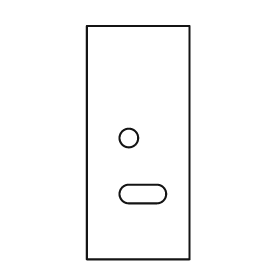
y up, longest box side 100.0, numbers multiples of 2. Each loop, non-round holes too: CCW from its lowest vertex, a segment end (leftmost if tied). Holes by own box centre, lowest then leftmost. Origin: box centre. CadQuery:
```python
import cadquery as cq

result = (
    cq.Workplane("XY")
    .moveTo(-22.0, -50.0)
    .lineTo(22.0, -50.0)
    .lineTo(22.0, 50.0)
    .lineTo(-22.0, 50.0)
    .close()
    .moveTo(-4.0, -26.0)
    .lineTo(8.0, -26.0)
    .threePointArc((12.0, -22.0), (8.0, -18.0))
    .lineTo(-4.0, -18.0)
    .threePointArc((-8.0, -22.0), (-4.0, -26.0))
    .close()
    .moveTo(-4.0, 2.0)
    .circle(4.0)
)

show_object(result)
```